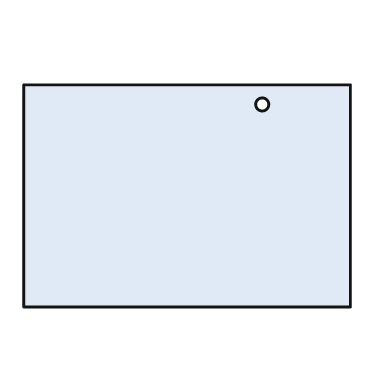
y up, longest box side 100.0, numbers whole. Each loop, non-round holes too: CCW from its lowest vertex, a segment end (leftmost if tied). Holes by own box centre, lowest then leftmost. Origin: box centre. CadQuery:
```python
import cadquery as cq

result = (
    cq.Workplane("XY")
    .moveTo(-50.0, -34.0)
    .lineTo(50.0, -34.0)
    .lineTo(50.0, 34.0)
    .lineTo(-50.0, 34.0)
    .close()
    .moveTo(23.0, 28.0)
    .circle(2.0)
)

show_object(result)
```